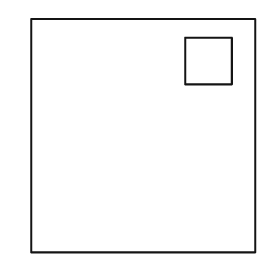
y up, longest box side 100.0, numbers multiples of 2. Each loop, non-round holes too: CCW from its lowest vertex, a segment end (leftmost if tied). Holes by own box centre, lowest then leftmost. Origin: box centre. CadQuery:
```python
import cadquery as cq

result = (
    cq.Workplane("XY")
    .moveTo(-48.0, -50.0)
    .lineTo(48.0, -50.0)
    .lineTo(48.0, 50.0)
    .lineTo(-48.0, 50.0)
    .close()
    .moveTo(18.0, 22.0)
    .lineTo(38.0, 22.0)
    .lineTo(38.0, 42.0)
    .lineTo(18.0, 42.0)
    .close()
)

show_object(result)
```